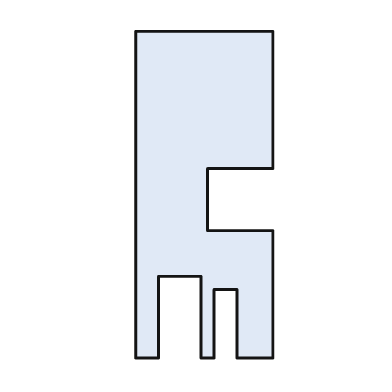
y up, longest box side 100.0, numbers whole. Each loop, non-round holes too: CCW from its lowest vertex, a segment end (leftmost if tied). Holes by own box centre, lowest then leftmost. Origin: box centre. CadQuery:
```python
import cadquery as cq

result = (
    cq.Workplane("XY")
    .moveTo(-21.0, -50.0)
    .lineTo(-14.0, -50.0)
    .lineTo(-14.0, -25.0)
    .lineTo(-1.0, -25.0)
    .lineTo(-1.0, -50.0)
    .lineTo(3.0, -50.0)
    .lineTo(3.0, -29.0)
    .lineTo(10.0, -29.0)
    .lineTo(10.0, -50.0)
    .lineTo(21.0, -50.0)
    .lineTo(21.0, -11.0)
    .lineTo(1.0, -11.0)
    .lineTo(1.0, 8.0)
    .lineTo(21.0, 8.0)
    .lineTo(21.0, 50.0)
    .lineTo(-21.0, 50.0)
    .close()
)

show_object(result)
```